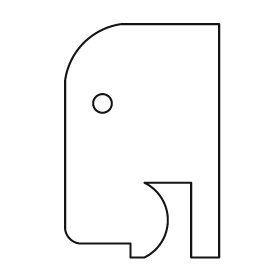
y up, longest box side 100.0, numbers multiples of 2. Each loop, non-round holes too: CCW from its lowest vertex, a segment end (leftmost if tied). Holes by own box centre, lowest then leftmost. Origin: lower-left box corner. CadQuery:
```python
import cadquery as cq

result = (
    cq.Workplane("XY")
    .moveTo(28.0, 0.0)
    .lineTo(34.0, 0.0)
    .threePointArc((44.0, 16.0), (34.0, 32.0))
    .lineTo(54.0, 32.0)
    .lineTo(54.0, 0.0)
    .lineTo(66.0, 0.0)
    .lineTo(66.0, 100.0)
    .lineTo(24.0, 100.0)
    .threePointArc((8.0, 92.0), (0.0, 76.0))
    .lineTo(0.0, 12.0)
    .threePointArc((2.0, 8.0), (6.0, 6.0))
    .lineTo(28.0, 6.0)
    .close()
    .moveTo(16.0, 66.0)
    .circle(4.0)
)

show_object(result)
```